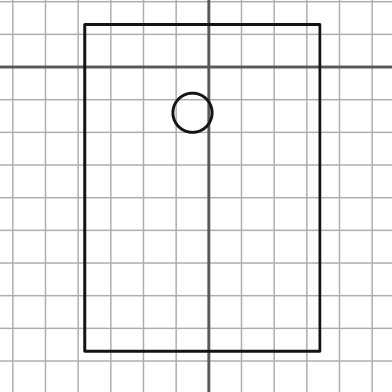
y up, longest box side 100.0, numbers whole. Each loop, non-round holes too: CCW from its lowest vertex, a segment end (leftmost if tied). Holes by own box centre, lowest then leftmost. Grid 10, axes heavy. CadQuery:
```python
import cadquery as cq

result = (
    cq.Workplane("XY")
    .moveTo(-38.0, -87.0)
    .lineTo(34.0, -87.0)
    .lineTo(34.0, 13.0)
    .lineTo(-38.0, 13.0)
    .close()
    .moveTo(-5.0, -14.0)
    .circle(6.0)
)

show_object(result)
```